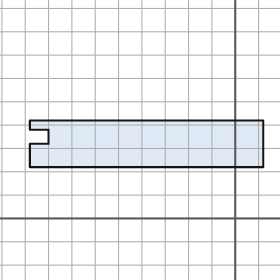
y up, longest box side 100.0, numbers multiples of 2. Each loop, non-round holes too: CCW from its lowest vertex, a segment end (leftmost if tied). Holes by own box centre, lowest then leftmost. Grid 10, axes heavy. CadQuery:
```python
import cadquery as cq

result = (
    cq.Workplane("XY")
    .moveTo(-88.0, 22.0)
    .lineTo(12.0, 22.0)
    .lineTo(12.0, 42.0)
    .lineTo(-88.0, 42.0)
    .lineTo(-88.0, 38.0)
    .lineTo(-80.0, 38.0)
    .lineTo(-80.0, 32.0)
    .lineTo(-88.0, 32.0)
    .close()
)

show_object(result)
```